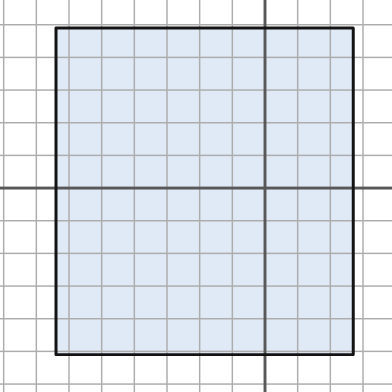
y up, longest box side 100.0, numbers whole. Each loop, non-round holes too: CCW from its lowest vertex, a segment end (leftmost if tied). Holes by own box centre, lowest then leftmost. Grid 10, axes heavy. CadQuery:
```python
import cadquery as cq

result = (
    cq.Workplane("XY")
    .moveTo(-64.0, -51.0)
    .lineTo(27.0, -51.0)
    .lineTo(27.0, 49.0)
    .lineTo(-64.0, 49.0)
    .close()
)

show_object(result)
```